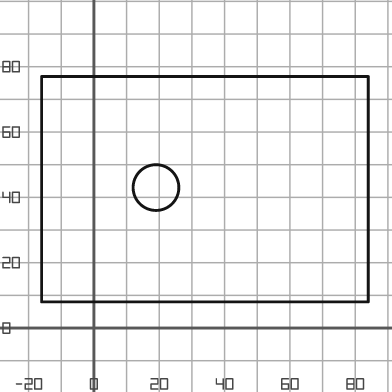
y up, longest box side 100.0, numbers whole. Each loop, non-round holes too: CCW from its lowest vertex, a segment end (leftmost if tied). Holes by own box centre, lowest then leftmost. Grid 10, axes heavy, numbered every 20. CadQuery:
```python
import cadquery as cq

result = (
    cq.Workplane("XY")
    .moveTo(-16.0, 8.0)
    .lineTo(84.0, 8.0)
    .lineTo(84.0, 77.0)
    .lineTo(-16.0, 77.0)
    .close()
    .moveTo(19.0, 43.0)
    .circle(7.0)
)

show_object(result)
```